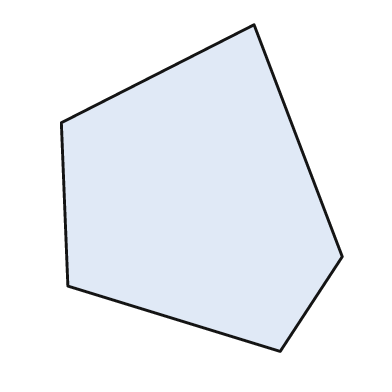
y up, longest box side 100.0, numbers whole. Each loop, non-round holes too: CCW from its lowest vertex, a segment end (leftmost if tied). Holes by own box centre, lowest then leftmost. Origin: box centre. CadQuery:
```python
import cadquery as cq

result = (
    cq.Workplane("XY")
    .moveTo(24.0, -50.0)
    .lineTo(43.0, -21.0)
    .lineTo(16.0, 50.0)
    .lineTo(-43.0, 20.0)
    .lineTo(-41.0, -30.0)
    .close()
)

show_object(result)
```